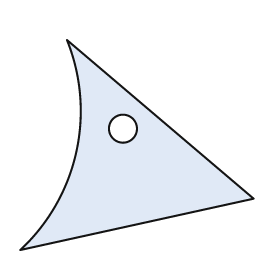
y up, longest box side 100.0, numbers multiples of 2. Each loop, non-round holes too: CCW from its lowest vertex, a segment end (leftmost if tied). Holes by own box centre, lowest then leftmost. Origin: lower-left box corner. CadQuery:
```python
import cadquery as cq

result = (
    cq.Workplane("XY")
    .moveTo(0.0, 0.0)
    .lineTo(100.0, 22.0)
    .lineTo(20.0, 90.0)
    .threePointArc((24.0, 42.0), (0.0, 0.0))
    .close()
    .moveTo(44.0, 52.0)
    .circle(6.0)
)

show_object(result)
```